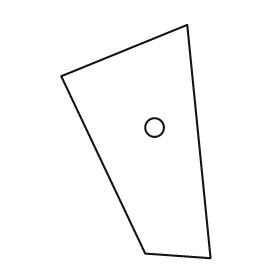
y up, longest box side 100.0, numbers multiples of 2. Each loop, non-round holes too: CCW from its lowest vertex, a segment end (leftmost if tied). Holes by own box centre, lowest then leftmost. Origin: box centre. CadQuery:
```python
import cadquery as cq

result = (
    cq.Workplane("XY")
    .moveTo(32.0, -50.0)
    .lineTo(22.0, 50.0)
    .lineTo(-32.0, 28.0)
    .lineTo(4.0, -48.0)
    .close()
    .moveTo(8.0, 6.0)
    .circle(4.0)
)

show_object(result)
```